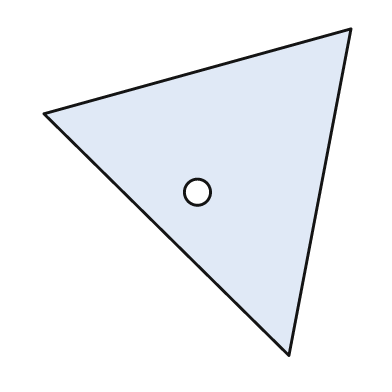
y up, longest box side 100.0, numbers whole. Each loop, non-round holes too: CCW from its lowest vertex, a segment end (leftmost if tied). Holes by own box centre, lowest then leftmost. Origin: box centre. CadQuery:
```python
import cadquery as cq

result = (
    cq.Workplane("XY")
    .moveTo(28.0, -50.0)
    .lineTo(47.0, 50.0)
    .lineTo(-47.0, 24.0)
    .close()
    .moveTo(0.0, 0.0)
    .circle(4.0)
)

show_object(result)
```